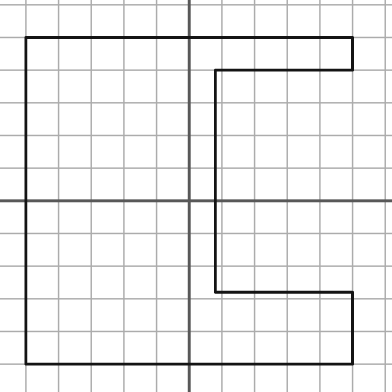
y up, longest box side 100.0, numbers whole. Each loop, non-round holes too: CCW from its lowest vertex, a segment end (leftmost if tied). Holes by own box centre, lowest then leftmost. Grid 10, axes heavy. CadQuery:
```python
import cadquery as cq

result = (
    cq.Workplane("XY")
    .moveTo(-50.0, -50.0)
    .lineTo(50.0, -50.0)
    .lineTo(50.0, -28.0)
    .lineTo(8.0, -28.0)
    .lineTo(8.0, 40.0)
    .lineTo(50.0, 40.0)
    .lineTo(50.0, 50.0)
    .lineTo(-50.0, 50.0)
    .close()
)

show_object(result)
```